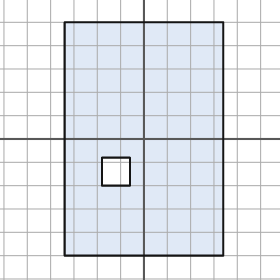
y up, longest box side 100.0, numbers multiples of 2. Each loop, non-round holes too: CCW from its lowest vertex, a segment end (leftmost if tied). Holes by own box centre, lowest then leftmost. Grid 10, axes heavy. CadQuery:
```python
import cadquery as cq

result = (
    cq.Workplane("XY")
    .moveTo(-34.0, -50.0)
    .lineTo(34.0, -50.0)
    .lineTo(34.0, 50.0)
    .lineTo(-34.0, 50.0)
    .close()
    .moveTo(-18.0, -20.0)
    .lineTo(-6.0, -20.0)
    .lineTo(-6.0, -8.0)
    .lineTo(-18.0, -8.0)
    .close()
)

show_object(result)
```